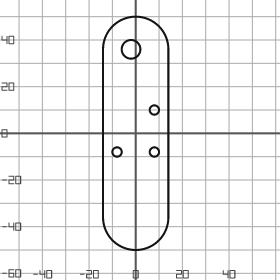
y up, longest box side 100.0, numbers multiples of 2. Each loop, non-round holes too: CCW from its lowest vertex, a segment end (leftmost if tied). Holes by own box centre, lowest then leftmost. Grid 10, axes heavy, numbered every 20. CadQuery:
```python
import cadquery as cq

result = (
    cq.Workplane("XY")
    .moveTo(-14.0, -36.0)
    .threePointArc((0.0, -50.0), (14.0, -36.0))
    .lineTo(14.0, 36.0)
    .threePointArc((0.0, 50.0), (-14.0, 36.0))
    .close()
    .moveTo(-8.0, -8.0)
    .circle(2.0)
    .moveTo(8.0, -8.0)
    .circle(2.0)
    .moveTo(8.0, 10.0)
    .circle(2.0)
    .moveTo(-2.0, 36.0)
    .circle(4.0)
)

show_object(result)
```